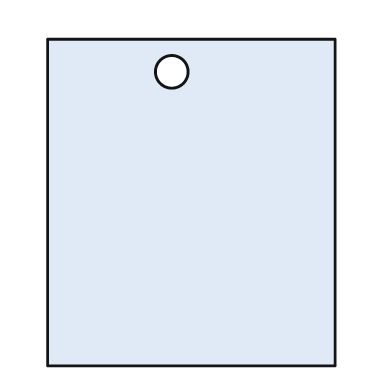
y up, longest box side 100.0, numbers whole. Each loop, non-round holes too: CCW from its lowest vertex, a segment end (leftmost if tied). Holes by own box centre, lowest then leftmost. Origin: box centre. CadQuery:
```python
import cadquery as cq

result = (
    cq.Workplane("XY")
    .moveTo(-44.0, -50.0)
    .lineTo(44.0, -50.0)
    .lineTo(44.0, 50.0)
    .lineTo(-44.0, 50.0)
    .close()
    .moveTo(-6.0, 40.0)
    .circle(5.0)
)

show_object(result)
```